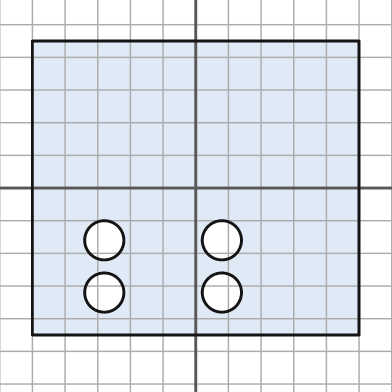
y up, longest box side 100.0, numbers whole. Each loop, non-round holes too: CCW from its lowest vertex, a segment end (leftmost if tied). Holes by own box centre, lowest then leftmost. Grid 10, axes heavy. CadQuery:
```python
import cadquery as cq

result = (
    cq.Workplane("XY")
    .moveTo(-50.0, -45.0)
    .lineTo(50.0, -45.0)
    .lineTo(50.0, 45.0)
    .lineTo(-50.0, 45.0)
    .close()
    .moveTo(-28.0, -32.0)
    .circle(6.0)
    .moveTo(8.0, -32.0)
    .circle(6.0)
    .moveTo(-28.0, -16.0)
    .circle(6.0)
    .moveTo(8.0, -16.0)
    .circle(6.0)
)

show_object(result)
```